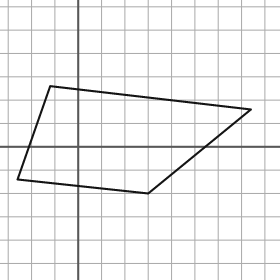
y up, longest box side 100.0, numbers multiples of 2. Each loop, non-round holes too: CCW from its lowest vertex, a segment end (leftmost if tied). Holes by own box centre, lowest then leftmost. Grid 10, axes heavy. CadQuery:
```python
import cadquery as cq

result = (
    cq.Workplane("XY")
    .moveTo(30.0, -20.0)
    .lineTo(74.0, 16.0)
    .lineTo(-12.0, 26.0)
    .lineTo(-26.0, -14.0)
    .close()
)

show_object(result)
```